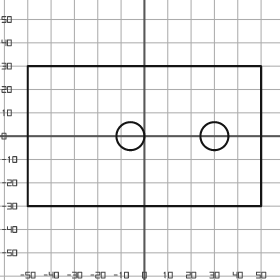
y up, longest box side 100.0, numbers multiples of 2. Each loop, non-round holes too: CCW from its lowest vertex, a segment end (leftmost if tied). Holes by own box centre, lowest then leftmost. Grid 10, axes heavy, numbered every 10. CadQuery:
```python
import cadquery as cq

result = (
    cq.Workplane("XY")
    .moveTo(-50.0, -30.0)
    .lineTo(50.0, -30.0)
    .lineTo(50.0, 30.0)
    .lineTo(-50.0, 30.0)
    .close()
    .moveTo(-6.0, 0.0)
    .circle(6.0)
    .moveTo(30.0, 0.0)
    .circle(6.0)
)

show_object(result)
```